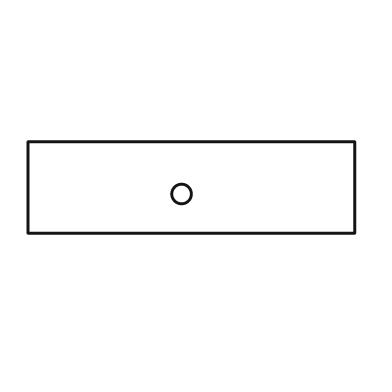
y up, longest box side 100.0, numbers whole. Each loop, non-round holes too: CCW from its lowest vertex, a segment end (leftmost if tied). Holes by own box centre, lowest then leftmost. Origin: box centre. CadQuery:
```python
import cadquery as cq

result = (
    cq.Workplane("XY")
    .moveTo(-50.0, -14.0)
    .lineTo(50.0, -14.0)
    .lineTo(50.0, 14.0)
    .lineTo(-50.0, 14.0)
    .close()
    .moveTo(-3.0, -2.0)
    .circle(3.0)
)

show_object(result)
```